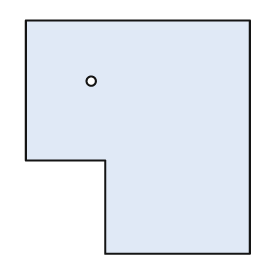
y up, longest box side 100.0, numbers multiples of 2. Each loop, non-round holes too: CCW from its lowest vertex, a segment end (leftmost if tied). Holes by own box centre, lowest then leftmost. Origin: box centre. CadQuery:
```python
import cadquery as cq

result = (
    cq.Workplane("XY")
    .moveTo(-14.0, -50.0)
    .lineTo(48.0, -50.0)
    .lineTo(48.0, 50.0)
    .lineTo(-48.0, 50.0)
    .lineTo(-48.0, -10.0)
    .lineTo(-14.0, -10.0)
    .close()
    .moveTo(-20.0, 24.0)
    .circle(2.0)
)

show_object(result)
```